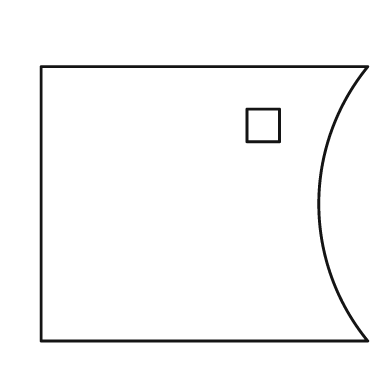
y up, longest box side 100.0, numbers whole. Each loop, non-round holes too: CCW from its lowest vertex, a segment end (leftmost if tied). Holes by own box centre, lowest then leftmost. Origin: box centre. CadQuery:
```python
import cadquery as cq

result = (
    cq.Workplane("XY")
    .moveTo(-50.0, -42.0)
    .lineTo(50.0, -42.0)
    .threePointArc((35.0, 0.0), (50.0, 42.0))
    .lineTo(-50.0, 42.0)
    .close()
    .moveTo(13.0, 19.0)
    .lineTo(23.0, 19.0)
    .lineTo(23.0, 29.0)
    .lineTo(13.0, 29.0)
    .close()
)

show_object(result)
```